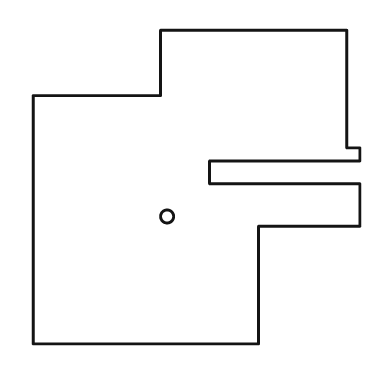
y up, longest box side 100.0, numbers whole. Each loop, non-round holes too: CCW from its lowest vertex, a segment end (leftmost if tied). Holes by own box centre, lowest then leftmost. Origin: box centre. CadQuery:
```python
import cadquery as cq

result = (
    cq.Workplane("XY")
    .moveTo(-50.0, -48.0)
    .lineTo(19.0, -48.0)
    .lineTo(19.0, -12.0)
    .lineTo(50.0, -12.0)
    .lineTo(50.0, 1.0)
    .lineTo(4.0, 1.0)
    .lineTo(4.0, 8.0)
    .lineTo(50.0, 8.0)
    .lineTo(50.0, 12.0)
    .lineTo(46.0, 12.0)
    .lineTo(46.0, 48.0)
    .lineTo(-11.0, 48.0)
    .lineTo(-11.0, 28.0)
    .lineTo(-50.0, 28.0)
    .close()
    .moveTo(-9.0, -9.0)
    .circle(2.0)
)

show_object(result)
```